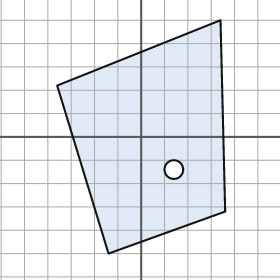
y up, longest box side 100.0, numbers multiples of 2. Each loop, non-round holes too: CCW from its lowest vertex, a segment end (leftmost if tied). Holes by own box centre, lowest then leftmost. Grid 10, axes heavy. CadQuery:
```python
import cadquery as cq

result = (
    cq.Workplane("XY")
    .moveTo(-14.0, -50.0)
    .lineTo(36.0, -32.0)
    .lineTo(34.0, 50.0)
    .lineTo(-36.0, 22.0)
    .close()
    .moveTo(14.0, -14.0)
    .circle(4.0)
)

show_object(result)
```